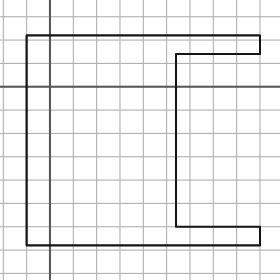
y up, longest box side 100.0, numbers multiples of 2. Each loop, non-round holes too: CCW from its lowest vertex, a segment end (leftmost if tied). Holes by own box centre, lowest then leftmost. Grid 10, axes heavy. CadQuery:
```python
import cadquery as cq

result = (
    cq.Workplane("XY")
    .moveTo(-10.0, -68.0)
    .lineTo(90.0, -68.0)
    .lineTo(90.0, -60.0)
    .lineTo(54.0, -60.0)
    .lineTo(54.0, 14.0)
    .lineTo(90.0, 14.0)
    .lineTo(90.0, 22.0)
    .lineTo(-10.0, 22.0)
    .close()
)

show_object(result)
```